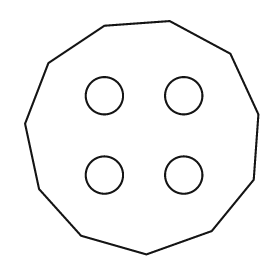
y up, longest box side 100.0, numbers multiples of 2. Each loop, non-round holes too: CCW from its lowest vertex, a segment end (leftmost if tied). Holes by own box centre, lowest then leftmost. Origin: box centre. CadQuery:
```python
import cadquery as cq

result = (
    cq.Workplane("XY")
    .moveTo(2.0, -50.0)
    .lineTo(30.0, -40.0)
    .lineTo(48.0, -18.0)
    .lineTo(50.0, 10.0)
    .lineTo(38.0, 36.0)
    .lineTo(12.0, 50.0)
    .lineTo(-16.0, 48.0)
    .lineTo(-40.0, 32.0)
    .lineTo(-50.0, 6.0)
    .lineTo(-44.0, -22.0)
    .lineTo(-26.0, -42.0)
    .close()
    .moveTo(-16.0, -16.0)
    .circle(8.0)
    .moveTo(18.0, -16.0)
    .circle(8.0)
    .moveTo(-16.0, 18.0)
    .circle(8.0)
    .moveTo(18.0, 18.0)
    .circle(8.0)
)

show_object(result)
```